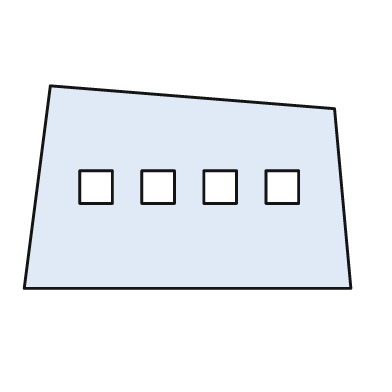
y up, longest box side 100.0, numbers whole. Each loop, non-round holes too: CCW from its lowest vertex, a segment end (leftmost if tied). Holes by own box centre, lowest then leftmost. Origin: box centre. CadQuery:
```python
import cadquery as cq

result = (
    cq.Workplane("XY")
    .moveTo(-50.0, -31.0)
    .lineTo(50.0, -31.0)
    .lineTo(45.0, 24.0)
    .lineTo(-42.0, 31.0)
    .close()
    .moveTo(-33.0, -5.0)
    .lineTo(-23.0, -5.0)
    .lineTo(-23.0, 5.0)
    .lineTo(-33.0, 5.0)
    .close()
    .moveTo(-14.0, -5.0)
    .lineTo(-4.0, -5.0)
    .lineTo(-4.0, 5.0)
    .lineTo(-14.0, 5.0)
    .close()
    .moveTo(5.0, -5.0)
    .lineTo(15.0, -5.0)
    .lineTo(15.0, 5.0)
    .lineTo(5.0, 5.0)
    .close()
    .moveTo(24.0, -5.0)
    .lineTo(34.0, -5.0)
    .lineTo(34.0, 5.0)
    .lineTo(24.0, 5.0)
    .close()
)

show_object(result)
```